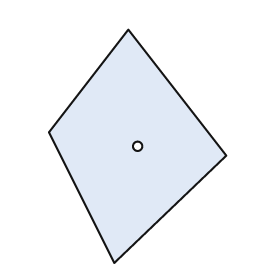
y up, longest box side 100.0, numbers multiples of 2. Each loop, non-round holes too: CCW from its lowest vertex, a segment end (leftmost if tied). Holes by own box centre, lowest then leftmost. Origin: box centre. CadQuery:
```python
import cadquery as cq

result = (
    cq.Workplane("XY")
    .moveTo(-10.0, -50.0)
    .lineTo(38.0, -4.0)
    .lineTo(-4.0, 50.0)
    .lineTo(-38.0, 6.0)
    .close()
    .moveTo(0.0, 0.0)
    .circle(2.0)
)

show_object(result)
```